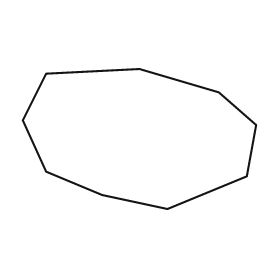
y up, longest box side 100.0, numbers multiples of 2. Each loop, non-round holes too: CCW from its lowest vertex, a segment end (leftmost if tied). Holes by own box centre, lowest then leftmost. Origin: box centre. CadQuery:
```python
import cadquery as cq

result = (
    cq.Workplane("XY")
    .moveTo(12.0, -30.0)
    .lineTo(46.0, -16.0)
    .lineTo(50.0, 6.0)
    .lineTo(34.0, 20.0)
    .lineTo(0.0, 30.0)
    .lineTo(-40.0, 28.0)
    .lineTo(-50.0, 8.0)
    .lineTo(-40.0, -14.0)
    .lineTo(-16.0, -24.0)
    .close()
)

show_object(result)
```